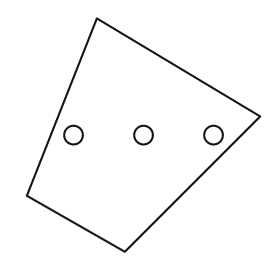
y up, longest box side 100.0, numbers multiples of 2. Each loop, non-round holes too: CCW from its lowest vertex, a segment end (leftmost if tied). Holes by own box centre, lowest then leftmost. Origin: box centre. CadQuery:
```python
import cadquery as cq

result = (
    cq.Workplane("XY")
    .moveTo(-8.0, -50.0)
    .lineTo(50.0, 8.0)
    .lineTo(-20.0, 50.0)
    .lineTo(-50.0, -26.0)
    .close()
    .moveTo(-30.0, 0.0)
    .circle(4.0)
    .moveTo(0.0, 0.0)
    .circle(4.0)
    .moveTo(30.0, 0.0)
    .circle(4.0)
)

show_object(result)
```